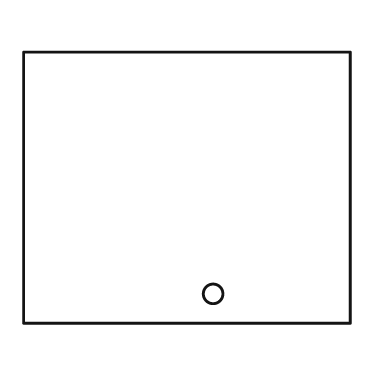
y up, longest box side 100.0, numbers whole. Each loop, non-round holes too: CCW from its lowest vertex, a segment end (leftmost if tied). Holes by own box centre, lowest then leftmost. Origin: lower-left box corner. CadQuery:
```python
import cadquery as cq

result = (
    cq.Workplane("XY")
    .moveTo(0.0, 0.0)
    .lineTo(100.0, 0.0)
    .lineTo(100.0, 83.0)
    .lineTo(0.0, 83.0)
    .close()
    .moveTo(58.0, 9.0)
    .circle(3.0)
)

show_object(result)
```